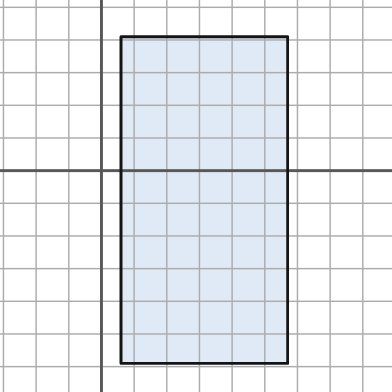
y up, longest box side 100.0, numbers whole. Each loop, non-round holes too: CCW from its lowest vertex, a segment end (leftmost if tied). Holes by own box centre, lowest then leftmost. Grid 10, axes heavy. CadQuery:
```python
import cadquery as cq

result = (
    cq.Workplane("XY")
    .moveTo(6.0, -59.0)
    .lineTo(57.0, -59.0)
    .lineTo(57.0, 41.0)
    .lineTo(6.0, 41.0)
    .close()
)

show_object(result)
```